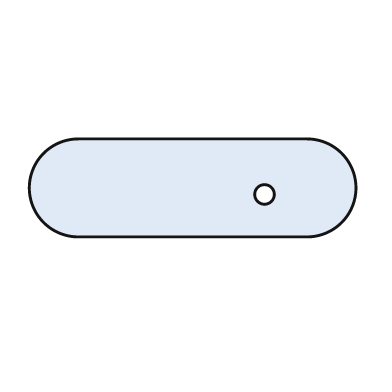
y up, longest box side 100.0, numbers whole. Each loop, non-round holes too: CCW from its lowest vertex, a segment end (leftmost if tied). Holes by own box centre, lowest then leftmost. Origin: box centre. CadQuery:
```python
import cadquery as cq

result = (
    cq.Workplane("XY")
    .moveTo(-35.0, -15.0)
    .lineTo(35.0, -15.0)
    .threePointArc((50.0, 0.0), (35.0, 15.0))
    .lineTo(-35.0, 15.0)
    .threePointArc((-50.0, 0.0), (-35.0, -15.0))
    .close()
    .moveTo(22.0, -2.0)
    .circle(3.0)
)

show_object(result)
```